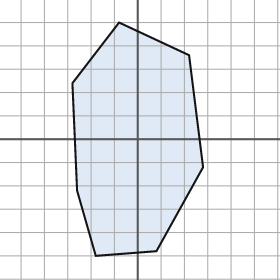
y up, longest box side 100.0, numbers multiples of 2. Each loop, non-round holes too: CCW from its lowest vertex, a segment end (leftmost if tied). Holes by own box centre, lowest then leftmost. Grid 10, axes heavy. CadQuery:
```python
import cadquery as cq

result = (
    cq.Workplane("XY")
    .moveTo(-18.0, -50.0)
    .lineTo(8.0, -48.0)
    .lineTo(28.0, -12.0)
    .lineTo(22.0, 36.0)
    .lineTo(-8.0, 50.0)
    .lineTo(-28.0, 24.0)
    .lineTo(-26.0, -22.0)
    .close()
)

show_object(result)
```